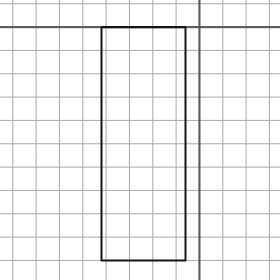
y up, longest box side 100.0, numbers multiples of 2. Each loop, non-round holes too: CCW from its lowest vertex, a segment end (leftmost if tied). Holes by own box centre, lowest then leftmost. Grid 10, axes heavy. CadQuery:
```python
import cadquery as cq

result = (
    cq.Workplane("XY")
    .moveTo(-42.0, -100.0)
    .lineTo(-6.0, -100.0)
    .lineTo(-6.0, 0.0)
    .lineTo(-42.0, 0.0)
    .close()
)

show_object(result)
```